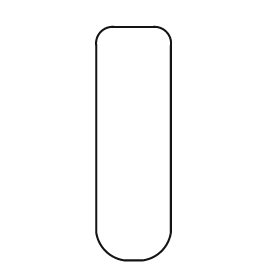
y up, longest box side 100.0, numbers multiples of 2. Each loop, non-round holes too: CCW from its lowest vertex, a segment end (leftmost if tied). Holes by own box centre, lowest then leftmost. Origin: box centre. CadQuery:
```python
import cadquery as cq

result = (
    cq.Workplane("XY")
    .moveTo(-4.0, -50.0)
    .lineTo(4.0, -50.0)
    .threePointArc((12.0, -46.0), (16.0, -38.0))
    .lineTo(16.0, 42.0)
    .threePointArc((14.0, 48.0), (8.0, 50.0))
    .lineTo(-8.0, 50.0)
    .threePointArc((-14.0, 48.0), (-16.0, 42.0))
    .lineTo(-16.0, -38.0)
    .threePointArc((-12.0, -46.0), (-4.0, -50.0))
    .close()
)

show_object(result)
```